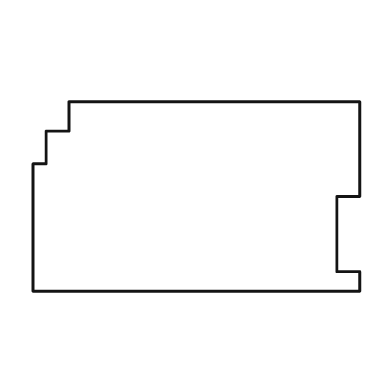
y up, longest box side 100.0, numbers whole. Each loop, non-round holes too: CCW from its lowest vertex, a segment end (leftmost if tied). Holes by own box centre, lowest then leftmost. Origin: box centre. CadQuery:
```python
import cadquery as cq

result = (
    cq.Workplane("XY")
    .moveTo(-50.0, -29.0)
    .lineTo(50.0, -29.0)
    .lineTo(50.0, -23.0)
    .lineTo(43.0, -23.0)
    .lineTo(43.0, 0.0)
    .lineTo(50.0, 0.0)
    .lineTo(50.0, 29.0)
    .lineTo(-39.0, 29.0)
    .lineTo(-39.0, 20.0)
    .lineTo(-46.0, 20.0)
    .lineTo(-46.0, 10.0)
    .lineTo(-50.0, 10.0)
    .close()
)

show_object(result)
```